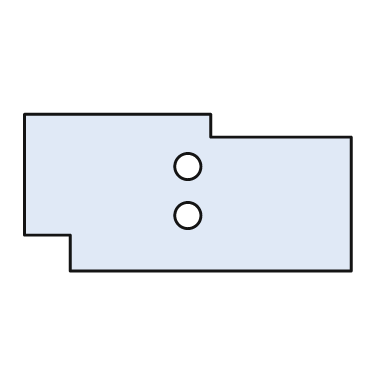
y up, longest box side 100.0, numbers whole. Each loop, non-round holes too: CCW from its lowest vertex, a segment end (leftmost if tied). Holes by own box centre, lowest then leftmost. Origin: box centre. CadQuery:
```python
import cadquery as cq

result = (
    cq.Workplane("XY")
    .moveTo(-36.0, -24.0)
    .lineTo(50.0, -24.0)
    .lineTo(50.0, 17.0)
    .lineTo(7.0, 17.0)
    .lineTo(7.0, 24.0)
    .lineTo(-50.0, 24.0)
    .lineTo(-50.0, -13.0)
    .lineTo(-36.0, -13.0)
    .close()
    .moveTo(0.0, -7.0)
    .circle(4.0)
    .moveTo(0.0, 8.0)
    .circle(4.0)
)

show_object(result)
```